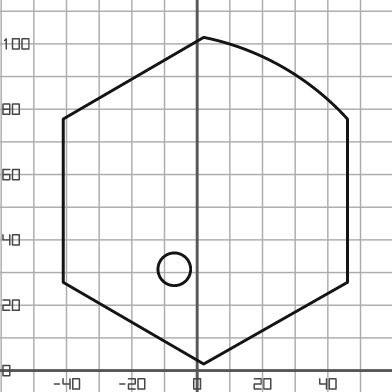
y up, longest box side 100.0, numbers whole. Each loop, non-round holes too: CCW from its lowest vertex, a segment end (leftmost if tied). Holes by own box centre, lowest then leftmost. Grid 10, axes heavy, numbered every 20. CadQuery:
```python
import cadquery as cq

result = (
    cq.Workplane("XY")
    .moveTo(2.0, 2.0)
    .lineTo(46.0, 27.0)
    .lineTo(46.0, 77.0)
    .threePointArc((26.0, 93.0), (2.0, 102.0))
    .lineTo(-41.0, 77.0)
    .lineTo(-41.0, 27.0)
    .close()
    .moveTo(-7.0, 31.0)
    .circle(5.0)
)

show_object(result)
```